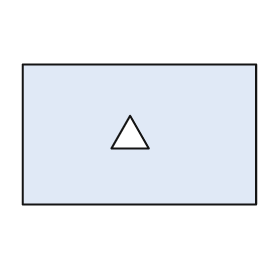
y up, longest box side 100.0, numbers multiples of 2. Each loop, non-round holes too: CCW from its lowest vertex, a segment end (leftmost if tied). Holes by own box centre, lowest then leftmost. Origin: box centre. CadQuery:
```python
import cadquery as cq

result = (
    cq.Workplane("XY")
    .moveTo(-50.0, -30.0)
    .lineTo(50.0, -30.0)
    .lineTo(50.0, 30.0)
    .lineTo(-50.0, 30.0)
    .close()
    .moveTo(-12.0, -6.0)
    .lineTo(4.0, -6.0)
    .lineTo(-4.0, 8.0)
    .close()
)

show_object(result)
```